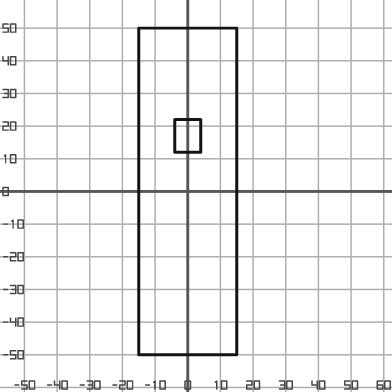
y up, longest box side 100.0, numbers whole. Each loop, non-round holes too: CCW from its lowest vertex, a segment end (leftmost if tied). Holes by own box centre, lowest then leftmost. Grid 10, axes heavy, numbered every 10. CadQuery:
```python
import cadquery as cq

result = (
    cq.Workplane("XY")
    .moveTo(-15.0, -50.0)
    .lineTo(15.0, -50.0)
    .lineTo(15.0, 50.0)
    .lineTo(-15.0, 50.0)
    .close()
    .moveTo(-4.0, 12.0)
    .lineTo(4.0, 12.0)
    .lineTo(4.0, 22.0)
    .lineTo(-4.0, 22.0)
    .close()
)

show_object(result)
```